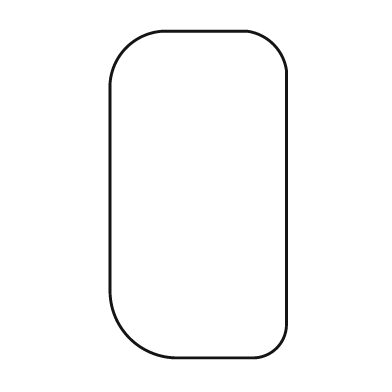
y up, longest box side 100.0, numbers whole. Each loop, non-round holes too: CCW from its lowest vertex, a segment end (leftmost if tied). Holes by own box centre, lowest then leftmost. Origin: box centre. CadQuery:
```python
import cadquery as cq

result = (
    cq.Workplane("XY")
    .moveTo(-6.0, -50.0)
    .lineTo(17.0, -50.0)
    .threePointArc((24.0, -47.0), (27.0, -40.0))
    .lineTo(27.0, 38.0)
    .threePointArc((23.0, 46.0), (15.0, 50.0))
    .lineTo(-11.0, 50.0)
    .threePointArc((-22.0, 45.0), (-27.0, 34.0))
    .lineTo(-27.0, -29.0)
    .threePointArc((-21.0, -44.0), (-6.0, -50.0))
    .close()
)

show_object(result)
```